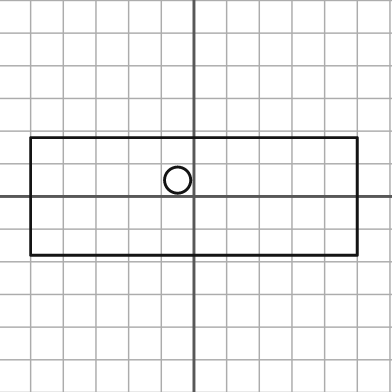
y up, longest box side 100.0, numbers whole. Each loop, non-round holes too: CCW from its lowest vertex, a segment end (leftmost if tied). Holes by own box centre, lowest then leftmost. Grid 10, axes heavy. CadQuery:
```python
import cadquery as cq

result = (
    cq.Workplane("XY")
    .moveTo(-50.0, -18.0)
    .lineTo(50.0, -18.0)
    .lineTo(50.0, 18.0)
    .lineTo(-50.0, 18.0)
    .close()
    .moveTo(-5.0, 5.0)
    .circle(4.0)
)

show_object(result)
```